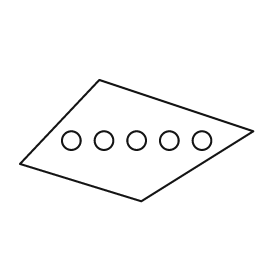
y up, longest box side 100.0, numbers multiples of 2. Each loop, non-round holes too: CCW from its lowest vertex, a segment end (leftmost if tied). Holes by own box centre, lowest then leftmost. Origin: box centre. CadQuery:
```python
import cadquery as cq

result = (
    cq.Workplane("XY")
    .moveTo(2.0, -26.0)
    .lineTo(50.0, 4.0)
    .lineTo(-16.0, 26.0)
    .lineTo(-50.0, -10.0)
    .close()
    .moveTo(-28.0, 0.0)
    .circle(4.0)
    .moveTo(-14.0, 0.0)
    .circle(4.0)
    .moveTo(0.0, 0.0)
    .circle(4.0)
    .moveTo(14.0, 0.0)
    .circle(4.0)
    .moveTo(28.0, 0.0)
    .circle(4.0)
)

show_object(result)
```